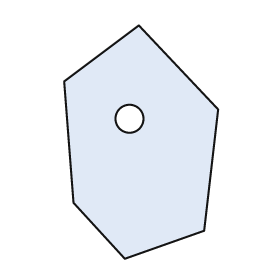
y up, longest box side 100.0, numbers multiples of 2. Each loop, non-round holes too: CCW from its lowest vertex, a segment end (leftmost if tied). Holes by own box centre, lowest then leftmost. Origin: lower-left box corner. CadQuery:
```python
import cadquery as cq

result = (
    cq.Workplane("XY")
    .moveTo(26.0, 0.0)
    .lineTo(60.0, 12.0)
    .lineTo(66.0, 64.0)
    .lineTo(32.0, 100.0)
    .lineTo(0.0, 76.0)
    .lineTo(4.0, 24.0)
    .close()
    .moveTo(28.0, 60.0)
    .circle(6.0)
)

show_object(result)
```